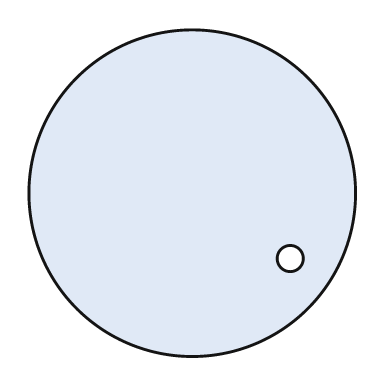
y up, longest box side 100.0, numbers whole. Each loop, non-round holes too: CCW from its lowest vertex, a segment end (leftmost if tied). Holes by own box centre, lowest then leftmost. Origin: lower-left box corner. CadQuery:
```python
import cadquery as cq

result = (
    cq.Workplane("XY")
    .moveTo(50.0, 50.0)
    .circle(50.0)
    .moveTo(80.0, 30.0)
    .circle(4.0)
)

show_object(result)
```